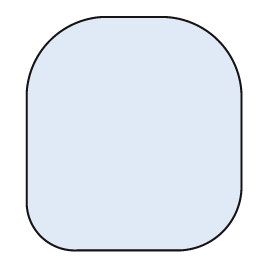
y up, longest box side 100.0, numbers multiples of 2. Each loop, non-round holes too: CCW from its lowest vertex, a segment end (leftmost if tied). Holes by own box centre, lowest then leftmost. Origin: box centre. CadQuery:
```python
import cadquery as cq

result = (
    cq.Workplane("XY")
    .moveTo(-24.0, -50.0)
    .lineTo(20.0, -50.0)
    .threePointArc((38.0, -42.0), (46.0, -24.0))
    .lineTo(46.0, 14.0)
    .threePointArc((36.0, 40.0), (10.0, 50.0))
    .lineTo(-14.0, 50.0)
    .threePointArc((-36.0, 40.0), (-46.0, 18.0))
    .lineTo(-46.0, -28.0)
    .threePointArc((-40.0, -44.0), (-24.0, -50.0))
    .close()
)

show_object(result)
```